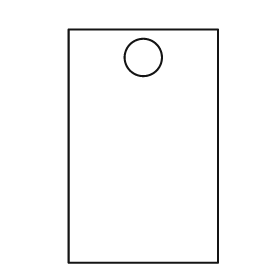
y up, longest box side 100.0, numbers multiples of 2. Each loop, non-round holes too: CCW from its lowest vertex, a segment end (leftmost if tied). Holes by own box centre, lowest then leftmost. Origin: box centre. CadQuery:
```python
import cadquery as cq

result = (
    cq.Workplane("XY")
    .moveTo(-32.0, -50.0)
    .lineTo(32.0, -50.0)
    .lineTo(32.0, 50.0)
    .lineTo(-32.0, 50.0)
    .close()
    .moveTo(0.0, 38.0)
    .circle(8.0)
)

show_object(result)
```